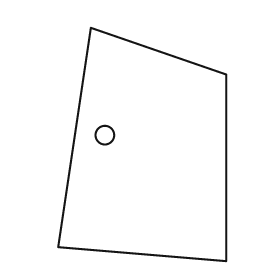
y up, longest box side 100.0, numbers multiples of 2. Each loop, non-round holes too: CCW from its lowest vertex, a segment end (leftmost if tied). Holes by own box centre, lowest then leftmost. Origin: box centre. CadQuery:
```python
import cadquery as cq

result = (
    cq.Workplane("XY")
    .moveTo(36.0, -50.0)
    .lineTo(36.0, 30.0)
    .lineTo(-22.0, 50.0)
    .lineTo(-36.0, -44.0)
    .close()
    .moveTo(-16.0, 4.0)
    .circle(4.0)
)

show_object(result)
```